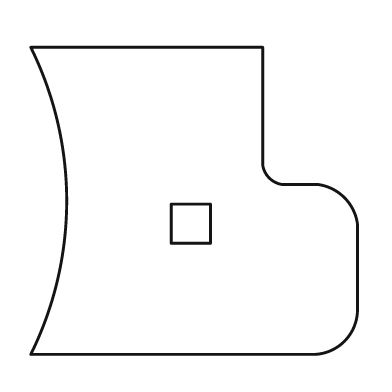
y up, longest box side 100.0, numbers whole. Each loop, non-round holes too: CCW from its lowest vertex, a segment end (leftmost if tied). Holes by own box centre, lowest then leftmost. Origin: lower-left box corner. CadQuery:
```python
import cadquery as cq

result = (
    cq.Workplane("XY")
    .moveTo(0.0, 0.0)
    .lineTo(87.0, 0.0)
    .threePointArc((96.0, 4.0), (100.0, 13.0))
    .lineTo(100.0, 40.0)
    .threePointArc((96.0, 48.0), (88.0, 52.0))
    .lineTo(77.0, 52.0)
    .threePointArc((73.0, 54.0), (71.0, 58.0))
    .lineTo(71.0, 94.0)
    .lineTo(0.0, 94.0)
    .threePointArc((11.0, 47.0), (0.0, 0.0))
    .close()
    .moveTo(43.0, 34.0)
    .lineTo(55.0, 34.0)
    .lineTo(55.0, 46.0)
    .lineTo(43.0, 46.0)
    .close()
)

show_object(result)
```